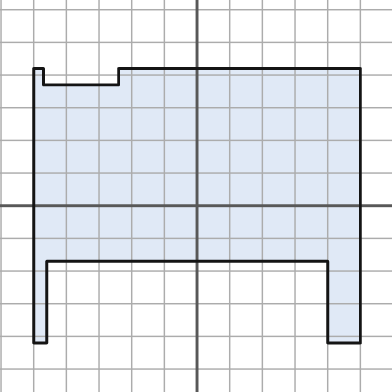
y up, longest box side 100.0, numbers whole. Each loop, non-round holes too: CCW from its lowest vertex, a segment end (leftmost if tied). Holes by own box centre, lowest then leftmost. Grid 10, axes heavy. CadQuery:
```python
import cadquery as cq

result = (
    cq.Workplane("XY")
    .moveTo(-50.0, -42.0)
    .lineTo(-46.0, -42.0)
    .lineTo(-46.0, -17.0)
    .lineTo(40.0, -17.0)
    .lineTo(40.0, -42.0)
    .lineTo(50.0, -42.0)
    .lineTo(50.0, 42.0)
    .lineTo(-24.0, 42.0)
    .lineTo(-24.0, 37.0)
    .lineTo(-47.0, 37.0)
    .lineTo(-47.0, 42.0)
    .lineTo(-50.0, 42.0)
    .close()
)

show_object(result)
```